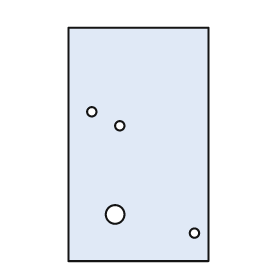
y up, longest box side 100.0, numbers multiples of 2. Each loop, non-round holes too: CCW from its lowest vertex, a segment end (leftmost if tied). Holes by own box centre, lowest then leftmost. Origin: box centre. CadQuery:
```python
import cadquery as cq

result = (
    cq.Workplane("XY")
    .moveTo(-30.0, -50.0)
    .lineTo(30.0, -50.0)
    .lineTo(30.0, 50.0)
    .lineTo(-30.0, 50.0)
    .close()
    .moveTo(24.0, -38.0)
    .circle(2.0)
    .moveTo(-10.0, -30.0)
    .circle(4.0)
    .moveTo(-8.0, 8.0)
    .circle(2.0)
    .moveTo(-20.0, 14.0)
    .circle(2.0)
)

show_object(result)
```